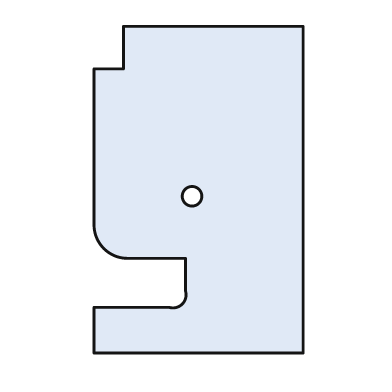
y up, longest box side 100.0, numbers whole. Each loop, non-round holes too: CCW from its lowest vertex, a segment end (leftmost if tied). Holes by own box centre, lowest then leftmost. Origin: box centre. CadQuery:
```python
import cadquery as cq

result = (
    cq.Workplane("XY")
    .moveTo(-32.0, -50.0)
    .lineTo(32.0, -50.0)
    .lineTo(32.0, 50.0)
    .lineTo(-23.0, 50.0)
    .lineTo(-23.0, 37.0)
    .lineTo(-32.0, 37.0)
    .lineTo(-32.0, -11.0)
    .threePointArc((-29.0, -18.0), (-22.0, -21.0))
    .lineTo(-4.0, -21.0)
    .lineTo(-4.0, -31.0)
    .threePointArc((-5.0, -35.0), (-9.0, -36.0))
    .lineTo(-32.0, -36.0)
    .close()
    .moveTo(-2.0, -2.0)
    .circle(3.0)
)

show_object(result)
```